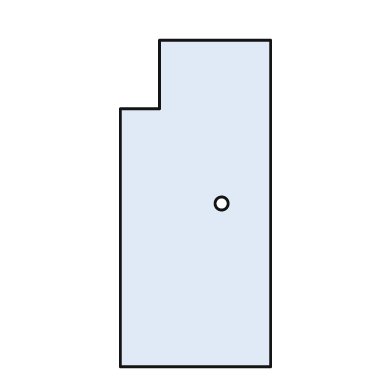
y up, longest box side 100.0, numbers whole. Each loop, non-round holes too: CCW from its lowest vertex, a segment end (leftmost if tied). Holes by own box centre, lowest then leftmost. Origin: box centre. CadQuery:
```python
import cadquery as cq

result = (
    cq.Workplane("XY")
    .moveTo(-23.0, -50.0)
    .lineTo(23.0, -50.0)
    .lineTo(23.0, 50.0)
    .lineTo(-11.0, 50.0)
    .lineTo(-11.0, 29.0)
    .lineTo(-23.0, 29.0)
    .close()
    .moveTo(8.0, 0.0)
    .circle(2.0)
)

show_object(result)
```